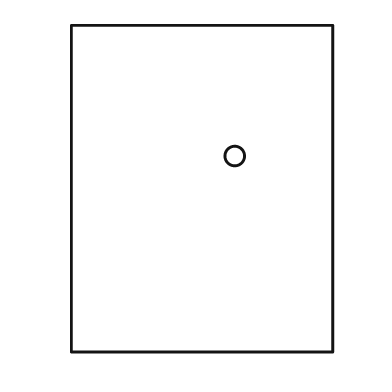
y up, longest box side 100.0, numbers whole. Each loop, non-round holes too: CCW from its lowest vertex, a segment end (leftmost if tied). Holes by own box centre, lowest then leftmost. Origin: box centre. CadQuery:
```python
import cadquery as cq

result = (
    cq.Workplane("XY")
    .moveTo(-40.0, -50.0)
    .lineTo(40.0, -50.0)
    .lineTo(40.0, 50.0)
    .lineTo(-40.0, 50.0)
    .close()
    .moveTo(10.0, 10.0)
    .circle(3.0)
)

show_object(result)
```